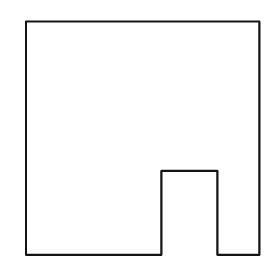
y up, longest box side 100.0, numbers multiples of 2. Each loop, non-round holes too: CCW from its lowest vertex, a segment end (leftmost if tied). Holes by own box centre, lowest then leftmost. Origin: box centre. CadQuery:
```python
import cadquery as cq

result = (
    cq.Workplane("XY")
    .moveTo(-50.0, -50.0)
    .lineTo(8.0, -50.0)
    .lineTo(8.0, -14.0)
    .lineTo(32.0, -14.0)
    .lineTo(32.0, -50.0)
    .lineTo(50.0, -50.0)
    .lineTo(50.0, 50.0)
    .lineTo(-50.0, 50.0)
    .close()
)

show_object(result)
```